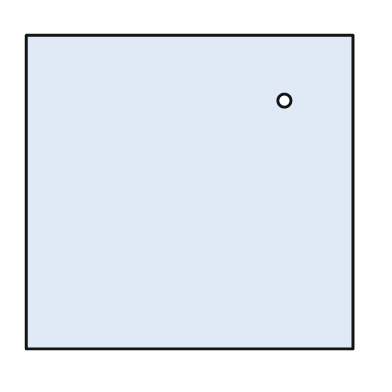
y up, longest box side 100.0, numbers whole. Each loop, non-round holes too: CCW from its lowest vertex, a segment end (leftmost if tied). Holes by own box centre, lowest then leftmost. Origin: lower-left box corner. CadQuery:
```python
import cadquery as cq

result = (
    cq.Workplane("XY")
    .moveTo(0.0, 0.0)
    .lineTo(100.0, 0.0)
    .lineTo(100.0, 96.0)
    .lineTo(0.0, 96.0)
    .close()
    .moveTo(79.0, 76.0)
    .circle(2.0)
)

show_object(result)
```